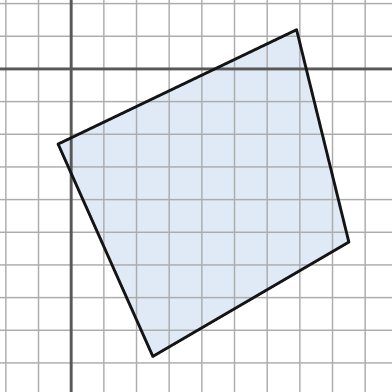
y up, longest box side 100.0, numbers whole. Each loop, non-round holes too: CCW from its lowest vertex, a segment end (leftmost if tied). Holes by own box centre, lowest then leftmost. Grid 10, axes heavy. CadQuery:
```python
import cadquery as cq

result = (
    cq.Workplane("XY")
    .moveTo(25.0, -88.0)
    .lineTo(85.0, -53.0)
    .lineTo(69.0, 12.0)
    .lineTo(-4.0, -23.0)
    .close()
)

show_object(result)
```